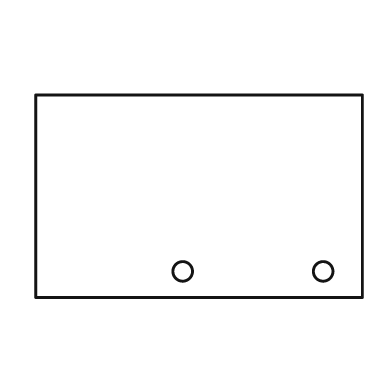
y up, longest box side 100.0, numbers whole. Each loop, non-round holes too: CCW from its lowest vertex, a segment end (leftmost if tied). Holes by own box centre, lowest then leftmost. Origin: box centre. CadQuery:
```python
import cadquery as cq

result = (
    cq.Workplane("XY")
    .moveTo(-50.0, -31.0)
    .lineTo(50.0, -31.0)
    .lineTo(50.0, 31.0)
    .lineTo(-50.0, 31.0)
    .close()
    .moveTo(-5.0, -23.0)
    .circle(3.0)
    .moveTo(38.0, -23.0)
    .circle(3.0)
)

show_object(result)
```